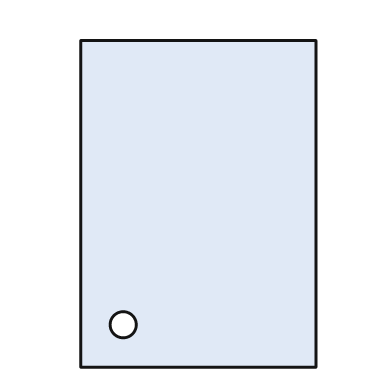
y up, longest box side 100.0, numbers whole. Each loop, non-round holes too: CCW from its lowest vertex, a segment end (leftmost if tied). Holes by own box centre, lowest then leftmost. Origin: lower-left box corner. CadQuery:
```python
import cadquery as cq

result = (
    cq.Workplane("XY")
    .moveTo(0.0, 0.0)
    .lineTo(72.0, 0.0)
    .lineTo(72.0, 100.0)
    .lineTo(0.0, 100.0)
    .close()
    .moveTo(13.0, 13.0)
    .circle(4.0)
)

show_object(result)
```